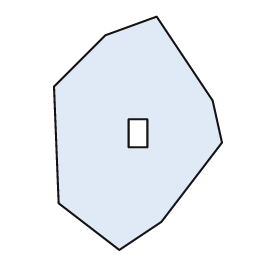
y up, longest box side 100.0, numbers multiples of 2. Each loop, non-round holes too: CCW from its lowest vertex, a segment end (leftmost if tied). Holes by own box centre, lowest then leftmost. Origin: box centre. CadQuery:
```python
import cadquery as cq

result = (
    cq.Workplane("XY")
    .moveTo(-8.0, -50.0)
    .lineTo(10.0, -38.0)
    .lineTo(36.0, -4.0)
    .lineTo(32.0, 14.0)
    .lineTo(8.0, 50.0)
    .lineTo(-14.0, 42.0)
    .lineTo(-36.0, 20.0)
    .lineTo(-34.0, -30.0)
    .close()
    .moveTo(-4.0, -6.0)
    .lineTo(4.0, -6.0)
    .lineTo(4.0, 6.0)
    .lineTo(-4.0, 6.0)
    .close()
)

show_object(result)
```